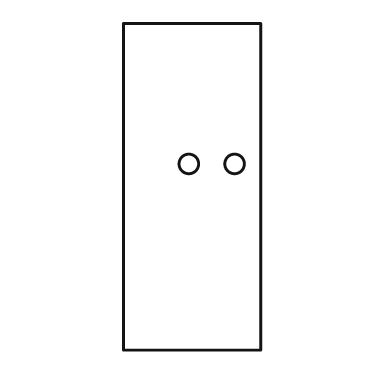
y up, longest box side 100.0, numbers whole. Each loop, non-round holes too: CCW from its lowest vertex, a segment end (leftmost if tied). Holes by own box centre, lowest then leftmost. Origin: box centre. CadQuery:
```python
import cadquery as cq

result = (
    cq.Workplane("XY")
    .moveTo(-21.0, -50.0)
    .lineTo(21.0, -50.0)
    .lineTo(21.0, 50.0)
    .lineTo(-21.0, 50.0)
    .close()
    .moveTo(-1.0, 7.0)
    .circle(3.0)
    .moveTo(13.0, 7.0)
    .circle(3.0)
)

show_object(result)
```